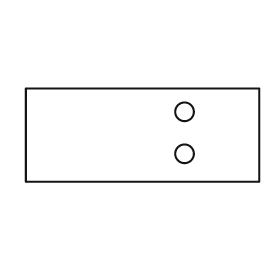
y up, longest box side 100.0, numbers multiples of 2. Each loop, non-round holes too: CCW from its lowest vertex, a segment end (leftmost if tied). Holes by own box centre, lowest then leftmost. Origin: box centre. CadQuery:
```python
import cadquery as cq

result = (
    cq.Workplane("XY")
    .moveTo(-50.0, -20.0)
    .lineTo(50.0, -20.0)
    .lineTo(50.0, 20.0)
    .lineTo(-50.0, 20.0)
    .close()
    .moveTo(18.0, -8.0)
    .circle(4.0)
    .moveTo(18.0, 10.0)
    .circle(4.0)
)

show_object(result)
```